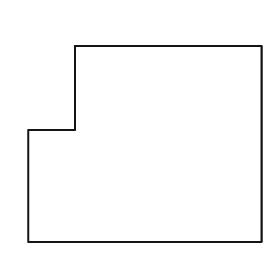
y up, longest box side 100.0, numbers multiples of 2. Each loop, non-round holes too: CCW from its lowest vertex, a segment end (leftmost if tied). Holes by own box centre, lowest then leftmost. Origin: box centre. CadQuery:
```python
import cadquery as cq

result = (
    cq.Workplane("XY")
    .moveTo(-50.0, -42.0)
    .lineTo(50.0, -42.0)
    .lineTo(50.0, 42.0)
    .lineTo(-30.0, 42.0)
    .lineTo(-30.0, 6.0)
    .lineTo(-50.0, 6.0)
    .close()
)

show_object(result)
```